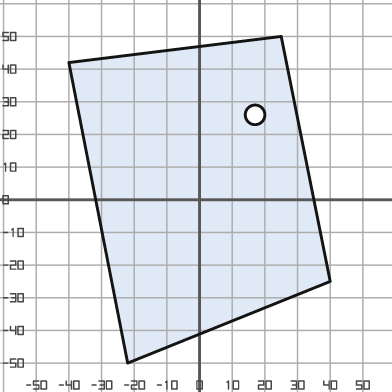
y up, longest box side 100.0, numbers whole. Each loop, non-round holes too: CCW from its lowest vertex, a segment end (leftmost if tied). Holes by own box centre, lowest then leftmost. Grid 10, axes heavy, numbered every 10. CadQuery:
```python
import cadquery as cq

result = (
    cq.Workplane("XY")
    .moveTo(-22.0, -50.0)
    .lineTo(40.0, -25.0)
    .lineTo(25.0, 50.0)
    .lineTo(-40.0, 42.0)
    .close()
    .moveTo(17.0, 26.0)
    .circle(3.0)
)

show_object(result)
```